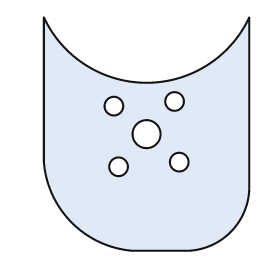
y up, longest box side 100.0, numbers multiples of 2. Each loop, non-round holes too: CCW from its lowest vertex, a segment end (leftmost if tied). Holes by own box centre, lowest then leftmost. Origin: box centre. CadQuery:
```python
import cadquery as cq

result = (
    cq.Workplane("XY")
    .moveTo(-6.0, -50.0)
    .lineTo(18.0, -50.0)
    .threePointArc((36.0, -42.0), (44.0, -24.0))
    .lineTo(44.0, 50.0)
    .threePointArc((0.0, 22.0), (-44.0, 50.0))
    .lineTo(-44.0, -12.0)
    .threePointArc((-32.0, -38.0), (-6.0, -50.0))
    .close()
    .moveTo(-12.0, -14.0)
    .circle(4.0)
    .moveTo(14.0, -12.0)
    .circle(4.0)
    .moveTo(0.0, 0.0)
    .circle(6.0)
    .moveTo(-14.0, 12.0)
    .circle(4.0)
    .moveTo(12.0, 14.0)
    .circle(4.0)
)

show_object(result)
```